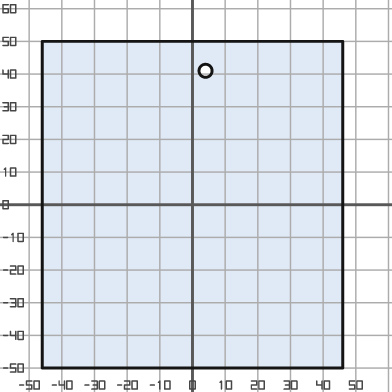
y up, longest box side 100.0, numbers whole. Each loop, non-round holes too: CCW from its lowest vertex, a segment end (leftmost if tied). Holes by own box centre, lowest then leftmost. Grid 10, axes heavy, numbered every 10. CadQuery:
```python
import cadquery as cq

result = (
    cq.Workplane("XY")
    .moveTo(-46.0, -50.0)
    .lineTo(46.0, -50.0)
    .lineTo(46.0, 50.0)
    .lineTo(-46.0, 50.0)
    .close()
    .moveTo(4.0, 41.0)
    .circle(2.0)
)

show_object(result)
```